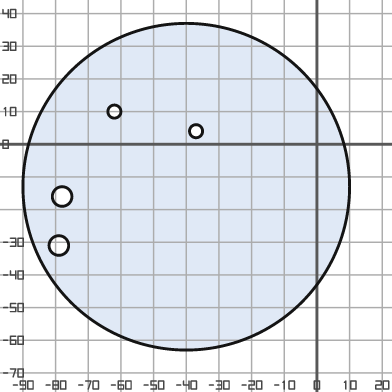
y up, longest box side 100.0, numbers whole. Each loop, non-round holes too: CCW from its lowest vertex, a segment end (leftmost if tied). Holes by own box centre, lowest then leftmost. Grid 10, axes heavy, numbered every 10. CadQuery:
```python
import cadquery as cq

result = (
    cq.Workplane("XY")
    .moveTo(-40.0, -13.0)
    .circle(50.0)
    .moveTo(-79.0, -31.0)
    .circle(3.0)
    .moveTo(-78.0, -16.0)
    .circle(3.0)
    .moveTo(-37.0, 4.0)
    .circle(2.0)
    .moveTo(-62.0, 10.0)
    .circle(2.0)
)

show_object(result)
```